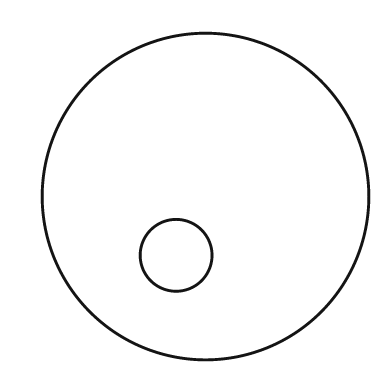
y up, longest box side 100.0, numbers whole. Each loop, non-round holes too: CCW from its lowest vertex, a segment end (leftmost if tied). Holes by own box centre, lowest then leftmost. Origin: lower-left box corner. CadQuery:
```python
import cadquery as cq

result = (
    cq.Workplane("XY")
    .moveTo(50.0, 50.0)
    .circle(50.0)
    .moveTo(41.0, 32.0)
    .circle(11.0)
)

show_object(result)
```